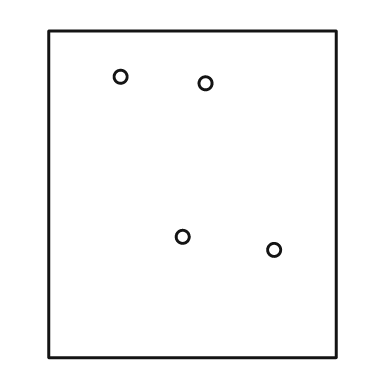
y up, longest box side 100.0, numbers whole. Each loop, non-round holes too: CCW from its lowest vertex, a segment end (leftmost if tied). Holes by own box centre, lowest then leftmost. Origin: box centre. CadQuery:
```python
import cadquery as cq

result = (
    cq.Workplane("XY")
    .moveTo(-44.0, -50.0)
    .lineTo(44.0, -50.0)
    .lineTo(44.0, 50.0)
    .lineTo(-44.0, 50.0)
    .close()
    .moveTo(25.0, -17.0)
    .circle(2.0)
    .moveTo(-3.0, -13.0)
    .circle(2.0)
    .moveTo(4.0, 34.0)
    .circle(2.0)
    .moveTo(-22.0, 36.0)
    .circle(2.0)
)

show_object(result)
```